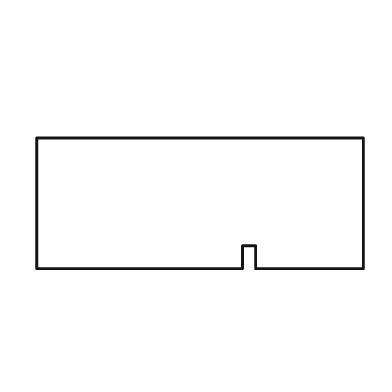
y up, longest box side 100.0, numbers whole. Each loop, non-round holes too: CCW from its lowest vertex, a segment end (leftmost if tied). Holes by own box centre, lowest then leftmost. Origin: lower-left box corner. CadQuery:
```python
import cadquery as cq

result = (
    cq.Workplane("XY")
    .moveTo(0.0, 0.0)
    .lineTo(63.0, 0.0)
    .lineTo(63.0, 7.0)
    .lineTo(67.0, 7.0)
    .lineTo(67.0, 0.0)
    .lineTo(100.0, 0.0)
    .lineTo(100.0, 40.0)
    .lineTo(0.0, 40.0)
    .close()
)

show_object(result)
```